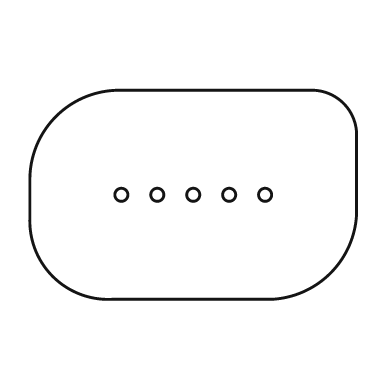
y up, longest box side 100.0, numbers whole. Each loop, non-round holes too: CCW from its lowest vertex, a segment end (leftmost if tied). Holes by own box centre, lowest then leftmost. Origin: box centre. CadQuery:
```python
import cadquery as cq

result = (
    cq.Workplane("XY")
    .moveTo(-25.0, -32.0)
    .lineTo(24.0, -32.0)
    .threePointArc((42.0, -24.0), (50.0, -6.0))
    .lineTo(50.0, 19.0)
    .threePointArc((46.0, 28.0), (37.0, 32.0))
    .lineTo(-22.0, 32.0)
    .threePointArc((-42.0, 24.0), (-50.0, 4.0))
    .lineTo(-50.0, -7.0)
    .threePointArc((-43.0, -25.0), (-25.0, -32.0))
    .close()
    .moveTo(-22.0, 0.0)
    .circle(2.0)
    .moveTo(-11.0, 0.0)
    .circle(2.0)
    .moveTo(0.0, 0.0)
    .circle(2.0)
    .moveTo(11.0, 0.0)
    .circle(2.0)
    .moveTo(22.0, 0.0)
    .circle(2.0)
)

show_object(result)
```